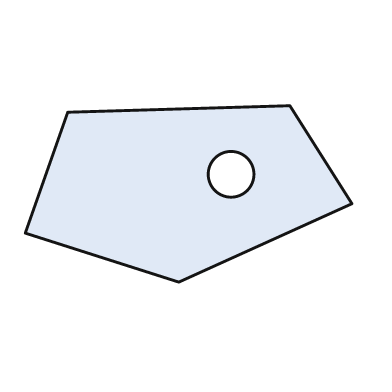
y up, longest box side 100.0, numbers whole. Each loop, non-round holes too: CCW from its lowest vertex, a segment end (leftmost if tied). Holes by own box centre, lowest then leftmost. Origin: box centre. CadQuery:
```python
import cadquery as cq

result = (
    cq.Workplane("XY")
    .moveTo(-3.0, -27.0)
    .lineTo(50.0, -3.0)
    .lineTo(31.0, 27.0)
    .lineTo(-37.0, 25.0)
    .lineTo(-50.0, -12.0)
    .close()
    .moveTo(13.0, 6.0)
    .circle(7.0)
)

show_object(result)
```